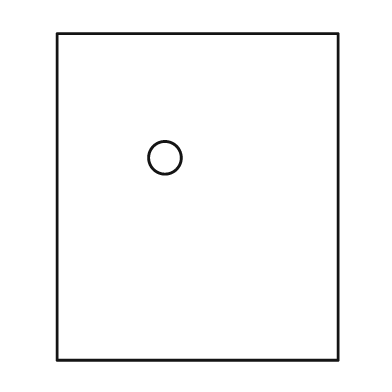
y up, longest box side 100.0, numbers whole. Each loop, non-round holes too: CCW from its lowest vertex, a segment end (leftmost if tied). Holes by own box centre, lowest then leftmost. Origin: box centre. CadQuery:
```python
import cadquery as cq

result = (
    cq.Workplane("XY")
    .moveTo(-43.0, -50.0)
    .lineTo(43.0, -50.0)
    .lineTo(43.0, 50.0)
    .lineTo(-43.0, 50.0)
    .close()
    .moveTo(-10.0, 12.0)
    .circle(5.0)
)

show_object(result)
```